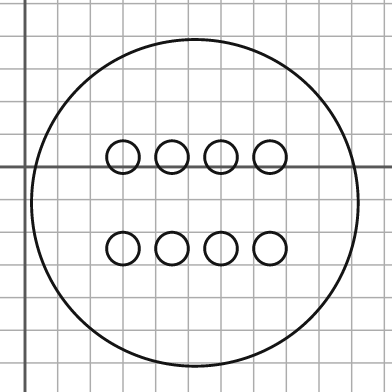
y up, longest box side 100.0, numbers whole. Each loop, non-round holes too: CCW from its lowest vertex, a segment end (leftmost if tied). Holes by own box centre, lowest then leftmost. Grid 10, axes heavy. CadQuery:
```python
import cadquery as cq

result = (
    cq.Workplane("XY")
    .moveTo(52.0, -11.0)
    .circle(50.0)
    .moveTo(30.0, -25.0)
    .circle(5.0)
    .moveTo(45.0, -25.0)
    .circle(5.0)
    .moveTo(60.0, -25.0)
    .circle(5.0)
    .moveTo(75.0, -25.0)
    .circle(5.0)
    .moveTo(30.0, 3.0)
    .circle(5.0)
    .moveTo(45.0, 3.0)
    .circle(5.0)
    .moveTo(60.0, 3.0)
    .circle(5.0)
    .moveTo(75.0, 3.0)
    .circle(5.0)
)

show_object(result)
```